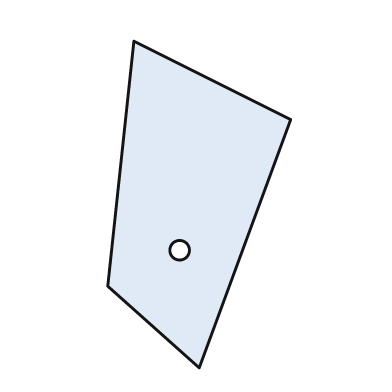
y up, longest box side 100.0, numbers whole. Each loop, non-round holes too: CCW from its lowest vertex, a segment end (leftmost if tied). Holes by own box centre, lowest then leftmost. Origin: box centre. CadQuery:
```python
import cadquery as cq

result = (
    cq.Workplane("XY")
    .moveTo(0.0, -50.0)
    .lineTo(28.0, 26.0)
    .lineTo(-20.0, 50.0)
    .lineTo(-28.0, -25.0)
    .close()
    .moveTo(-6.0, -14.0)
    .circle(3.0)
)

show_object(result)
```